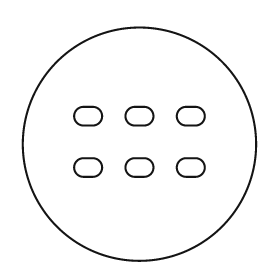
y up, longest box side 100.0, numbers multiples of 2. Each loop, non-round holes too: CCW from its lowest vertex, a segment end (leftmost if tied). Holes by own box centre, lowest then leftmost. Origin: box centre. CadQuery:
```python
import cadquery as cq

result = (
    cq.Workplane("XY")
    .moveTo(0.0, 0.0)
    .circle(50.0)
    .moveTo(-24.0, -14.0)
    .lineTo(-20.0, -14.0)
    .threePointArc((-16.0, -10.0), (-20.0, -6.0))
    .lineTo(-24.0, -6.0)
    .threePointArc((-28.0, -10.0), (-24.0, -14.0))
    .close()
    .moveTo(-2.0, -14.0)
    .lineTo(2.0, -14.0)
    .threePointArc((6.0, -10.0), (2.0, -6.0))
    .lineTo(-2.0, -6.0)
    .threePointArc((-6.0, -10.0), (-2.0, -14.0))
    .close()
    .moveTo(20.0, -14.0)
    .lineTo(24.0, -14.0)
    .threePointArc((28.0, -10.0), (24.0, -6.0))
    .lineTo(20.0, -6.0)
    .threePointArc((16.0, -10.0), (20.0, -14.0))
    .close()
    .moveTo(-24.0, 8.0)
    .lineTo(-20.0, 8.0)
    .threePointArc((-16.0, 12.0), (-20.0, 16.0))
    .lineTo(-24.0, 16.0)
    .threePointArc((-28.0, 12.0), (-24.0, 8.0))
    .close()
    .moveTo(-2.0, 8.0)
    .lineTo(2.0, 8.0)
    .threePointArc((6.0, 12.0), (2.0, 16.0))
    .lineTo(-2.0, 16.0)
    .threePointArc((-6.0, 12.0), (-2.0, 8.0))
    .close()
    .moveTo(20.0, 8.0)
    .lineTo(24.0, 8.0)
    .threePointArc((28.0, 12.0), (24.0, 16.0))
    .lineTo(20.0, 16.0)
    .threePointArc((16.0, 12.0), (20.0, 8.0))
    .close()
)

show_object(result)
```